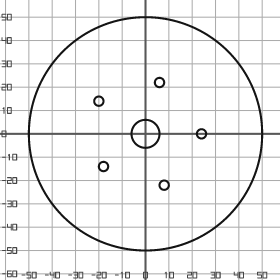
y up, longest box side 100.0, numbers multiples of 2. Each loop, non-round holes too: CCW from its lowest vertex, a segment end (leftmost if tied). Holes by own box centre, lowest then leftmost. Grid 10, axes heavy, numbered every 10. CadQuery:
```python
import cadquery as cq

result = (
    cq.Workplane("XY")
    .moveTo(0.0, 0.0)
    .circle(50.0)
    .moveTo(8.0, -22.0)
    .circle(2.0)
    .moveTo(-18.0, -14.0)
    .circle(2.0)
    .moveTo(0.0, 0.0)
    .circle(6.0)
    .moveTo(24.0, 0.0)
    .circle(2.0)
    .moveTo(-20.0, 14.0)
    .circle(2.0)
    .moveTo(6.0, 22.0)
    .circle(2.0)
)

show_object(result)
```